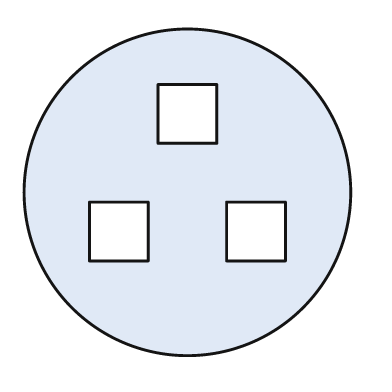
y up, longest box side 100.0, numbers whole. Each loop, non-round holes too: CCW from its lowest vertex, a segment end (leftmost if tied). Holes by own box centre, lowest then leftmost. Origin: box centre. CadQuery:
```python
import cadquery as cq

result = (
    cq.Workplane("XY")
    .moveTo(0.0, 0.0)
    .circle(50.0)
    .moveTo(-30.0, -21.0)
    .lineTo(-12.0, -21.0)
    .lineTo(-12.0, -3.0)
    .lineTo(-30.0, -3.0)
    .close()
    .moveTo(12.0, -21.0)
    .lineTo(30.0, -21.0)
    .lineTo(30.0, -3.0)
    .lineTo(12.0, -3.0)
    .close()
    .moveTo(-9.0, 15.0)
    .lineTo(9.0, 15.0)
    .lineTo(9.0, 33.0)
    .lineTo(-9.0, 33.0)
    .close()
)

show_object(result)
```